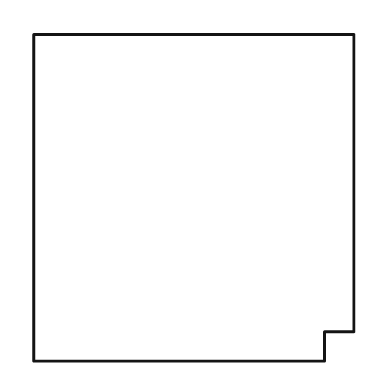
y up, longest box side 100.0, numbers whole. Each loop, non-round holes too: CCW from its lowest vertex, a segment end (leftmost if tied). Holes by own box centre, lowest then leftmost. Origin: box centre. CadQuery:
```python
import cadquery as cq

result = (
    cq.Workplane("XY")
    .moveTo(-49.0, -50.0)
    .lineTo(40.0, -50.0)
    .lineTo(40.0, -41.0)
    .lineTo(49.0, -41.0)
    .lineTo(49.0, 50.0)
    .lineTo(-49.0, 50.0)
    .close()
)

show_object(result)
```